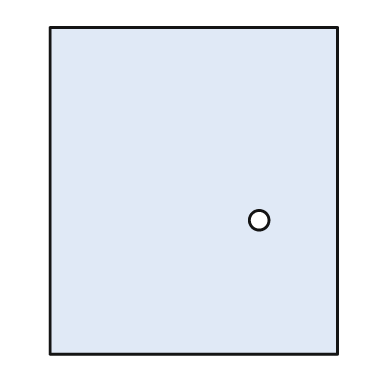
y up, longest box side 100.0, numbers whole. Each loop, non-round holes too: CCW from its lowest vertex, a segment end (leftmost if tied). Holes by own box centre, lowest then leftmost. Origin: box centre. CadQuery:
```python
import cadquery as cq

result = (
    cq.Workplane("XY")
    .moveTo(-44.0, -50.0)
    .lineTo(44.0, -50.0)
    .lineTo(44.0, 50.0)
    .lineTo(-44.0, 50.0)
    .close()
    .moveTo(20.0, -9.0)
    .circle(3.0)
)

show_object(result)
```